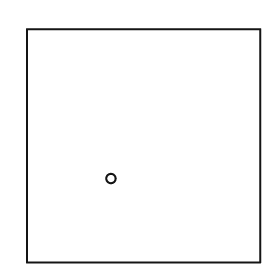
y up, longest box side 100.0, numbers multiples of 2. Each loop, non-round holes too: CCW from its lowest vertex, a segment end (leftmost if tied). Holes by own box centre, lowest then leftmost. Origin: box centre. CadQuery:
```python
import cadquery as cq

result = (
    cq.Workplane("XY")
    .moveTo(-50.0, -50.0)
    .lineTo(50.0, -50.0)
    .lineTo(50.0, 50.0)
    .lineTo(-50.0, 50.0)
    .close()
    .moveTo(-14.0, -14.0)
    .circle(2.0)
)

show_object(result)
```